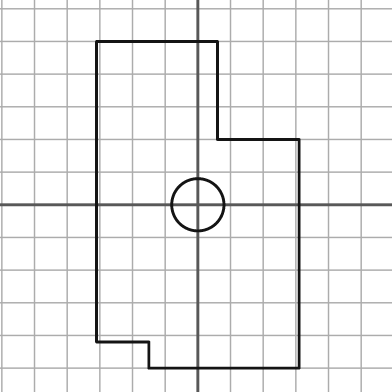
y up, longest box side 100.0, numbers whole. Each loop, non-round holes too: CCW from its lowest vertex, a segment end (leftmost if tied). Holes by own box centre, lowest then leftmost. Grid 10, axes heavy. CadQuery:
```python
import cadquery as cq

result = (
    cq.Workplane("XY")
    .moveTo(-15.0, -50.0)
    .lineTo(31.0, -50.0)
    .lineTo(31.0, 20.0)
    .lineTo(6.0, 20.0)
    .lineTo(6.0, 50.0)
    .lineTo(-31.0, 50.0)
    .lineTo(-31.0, -42.0)
    .lineTo(-15.0, -42.0)
    .close()
    .moveTo(0.0, 0.0)
    .circle(8.0)
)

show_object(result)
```